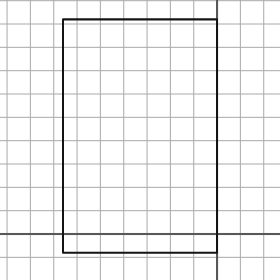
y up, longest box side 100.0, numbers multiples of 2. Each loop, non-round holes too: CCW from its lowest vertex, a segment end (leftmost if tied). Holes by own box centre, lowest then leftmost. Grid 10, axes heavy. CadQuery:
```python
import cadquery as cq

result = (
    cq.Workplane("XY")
    .moveTo(-66.0, -8.0)
    .lineTo(0.0, -8.0)
    .lineTo(0.0, 92.0)
    .lineTo(-66.0, 92.0)
    .close()
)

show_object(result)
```